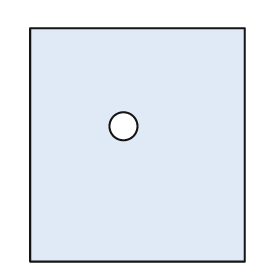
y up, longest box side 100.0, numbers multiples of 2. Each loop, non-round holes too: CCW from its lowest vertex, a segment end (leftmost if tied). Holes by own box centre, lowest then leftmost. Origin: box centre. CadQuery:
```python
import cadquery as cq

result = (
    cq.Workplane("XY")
    .moveTo(-46.0, -50.0)
    .lineTo(46.0, -50.0)
    .lineTo(46.0, 50.0)
    .lineTo(-46.0, 50.0)
    .close()
    .moveTo(-6.0, 8.0)
    .circle(6.0)
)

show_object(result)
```